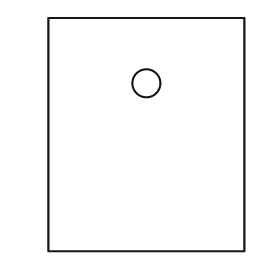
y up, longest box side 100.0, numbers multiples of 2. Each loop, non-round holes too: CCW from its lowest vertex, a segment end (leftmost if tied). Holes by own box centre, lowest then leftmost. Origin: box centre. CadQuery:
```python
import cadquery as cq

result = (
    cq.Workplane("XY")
    .moveTo(-42.0, -50.0)
    .lineTo(42.0, -50.0)
    .lineTo(42.0, 50.0)
    .lineTo(-42.0, 50.0)
    .close()
    .moveTo(0.0, 22.0)
    .circle(6.0)
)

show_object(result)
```